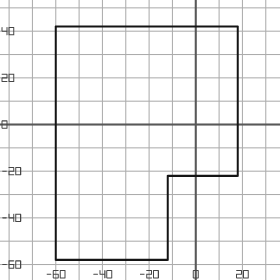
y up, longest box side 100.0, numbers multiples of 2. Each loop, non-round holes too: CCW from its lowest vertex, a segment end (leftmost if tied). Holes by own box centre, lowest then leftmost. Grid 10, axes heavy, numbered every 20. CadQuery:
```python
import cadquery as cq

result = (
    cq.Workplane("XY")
    .moveTo(-60.0, -58.0)
    .lineTo(-12.0, -58.0)
    .lineTo(-12.0, -22.0)
    .lineTo(18.0, -22.0)
    .lineTo(18.0, 42.0)
    .lineTo(-60.0, 42.0)
    .close()
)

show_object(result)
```